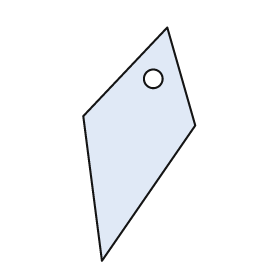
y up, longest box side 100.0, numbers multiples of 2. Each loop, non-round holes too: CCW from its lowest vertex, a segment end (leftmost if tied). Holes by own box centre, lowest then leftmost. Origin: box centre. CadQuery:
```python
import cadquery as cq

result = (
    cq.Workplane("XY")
    .moveTo(-16.0, -50.0)
    .lineTo(24.0, 8.0)
    .lineTo(12.0, 50.0)
    .lineTo(-24.0, 12.0)
    .close()
    .moveTo(6.0, 28.0)
    .circle(4.0)
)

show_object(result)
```